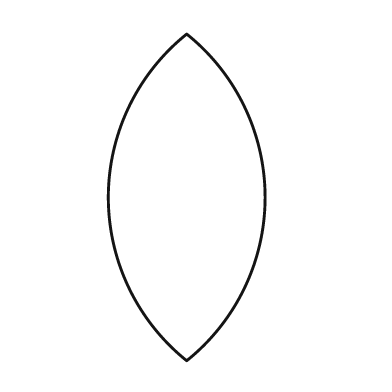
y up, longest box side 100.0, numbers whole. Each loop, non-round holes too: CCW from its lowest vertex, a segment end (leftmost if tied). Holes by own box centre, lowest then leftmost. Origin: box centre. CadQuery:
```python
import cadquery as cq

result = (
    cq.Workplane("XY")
    .moveTo(0.0, -50.0)
    .threePointArc((24.0, 0.0), (0.0, 50.0))
    .threePointArc((-24.0, 0.0), (0.0, -50.0))
    .close()
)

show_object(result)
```